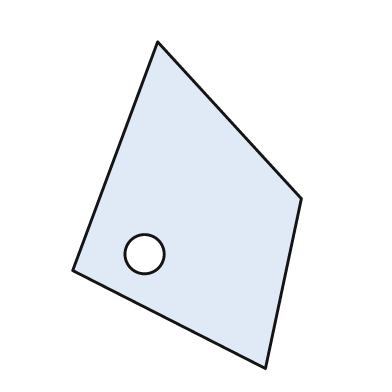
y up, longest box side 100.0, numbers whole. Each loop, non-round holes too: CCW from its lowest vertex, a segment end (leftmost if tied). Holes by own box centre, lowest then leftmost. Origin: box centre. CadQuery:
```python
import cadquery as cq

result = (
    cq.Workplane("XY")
    .moveTo(24.0, -50.0)
    .lineTo(35.0, 2.0)
    .lineTo(-9.0, 50.0)
    .lineTo(-35.0, -20.0)
    .close()
    .moveTo(-13.0, -15.0)
    .circle(6.0)
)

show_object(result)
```